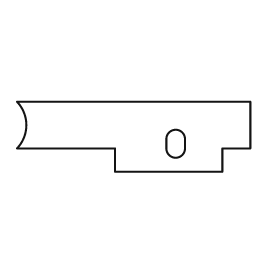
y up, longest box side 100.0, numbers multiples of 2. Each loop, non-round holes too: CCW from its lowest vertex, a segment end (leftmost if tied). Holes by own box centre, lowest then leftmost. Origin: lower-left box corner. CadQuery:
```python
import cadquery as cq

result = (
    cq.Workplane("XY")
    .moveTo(42.0, 0.0)
    .lineTo(88.0, 0.0)
    .lineTo(88.0, 10.0)
    .lineTo(100.0, 10.0)
    .lineTo(100.0, 30.0)
    .lineTo(0.0, 30.0)
    .threePointArc((4.0, 20.0), (0.0, 10.0))
    .lineTo(42.0, 10.0)
    .close()
    .moveTo(64.0, 10.0)
    .threePointArc((68.0, 6.0), (72.0, 10.0))
    .lineTo(72.0, 14.0)
    .threePointArc((68.0, 18.0), (64.0, 14.0))
    .close()
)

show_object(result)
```